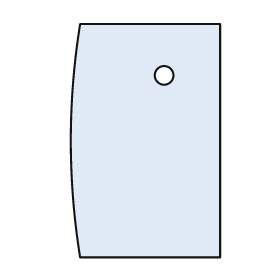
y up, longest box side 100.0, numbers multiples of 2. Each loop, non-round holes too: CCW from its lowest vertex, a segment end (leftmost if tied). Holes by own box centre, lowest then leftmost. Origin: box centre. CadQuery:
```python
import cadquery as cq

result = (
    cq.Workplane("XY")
    .moveTo(-28.0, -50.0)
    .lineTo(32.0, -50.0)
    .lineTo(32.0, 50.0)
    .lineTo(-28.0, 50.0)
    .threePointArc((-32.0, 0.0), (-28.0, -50.0))
    .close()
    .moveTo(8.0, 28.0)
    .circle(4.0)
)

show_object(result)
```